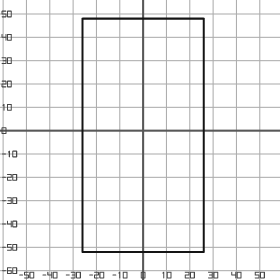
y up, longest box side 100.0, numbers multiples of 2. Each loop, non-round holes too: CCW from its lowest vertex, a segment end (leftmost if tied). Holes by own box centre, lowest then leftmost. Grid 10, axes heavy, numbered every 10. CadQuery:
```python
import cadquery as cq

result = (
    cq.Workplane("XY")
    .moveTo(-26.0, -52.0)
    .lineTo(26.0, -52.0)
    .lineTo(26.0, 48.0)
    .lineTo(-26.0, 48.0)
    .close()
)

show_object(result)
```